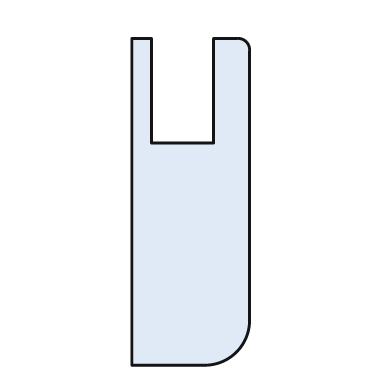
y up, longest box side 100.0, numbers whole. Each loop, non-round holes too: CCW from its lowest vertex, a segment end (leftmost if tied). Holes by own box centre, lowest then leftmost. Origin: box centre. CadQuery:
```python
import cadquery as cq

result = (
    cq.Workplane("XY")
    .moveTo(-18.0, -50.0)
    .lineTo(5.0, -50.0)
    .threePointArc((14.0, -46.0), (18.0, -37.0))
    .lineTo(18.0, 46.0)
    .threePointArc((17.0, 49.0), (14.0, 50.0))
    .lineTo(7.0, 50.0)
    .lineTo(7.0, 18.0)
    .lineTo(-12.0, 18.0)
    .lineTo(-12.0, 50.0)
    .lineTo(-18.0, 50.0)
    .close()
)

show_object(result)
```